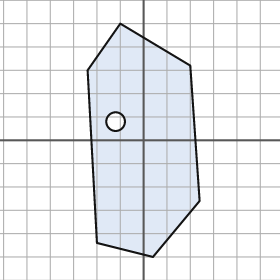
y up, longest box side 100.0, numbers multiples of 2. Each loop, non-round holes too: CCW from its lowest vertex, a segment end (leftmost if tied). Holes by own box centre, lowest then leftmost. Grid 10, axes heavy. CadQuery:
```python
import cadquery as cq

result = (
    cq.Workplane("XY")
    .moveTo(4.0, -50.0)
    .lineTo(24.0, -26.0)
    .lineTo(20.0, 32.0)
    .lineTo(-10.0, 50.0)
    .lineTo(-24.0, 30.0)
    .lineTo(-20.0, -44.0)
    .close()
    .moveTo(-12.0, 8.0)
    .circle(4.0)
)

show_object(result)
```